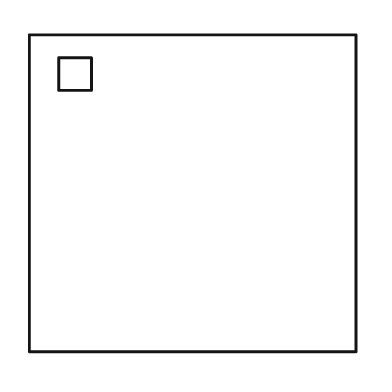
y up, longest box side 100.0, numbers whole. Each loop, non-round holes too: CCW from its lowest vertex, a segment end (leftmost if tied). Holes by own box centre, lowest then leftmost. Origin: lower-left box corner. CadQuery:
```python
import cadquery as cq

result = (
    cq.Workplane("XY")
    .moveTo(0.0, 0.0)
    .lineTo(100.0, 0.0)
    .lineTo(100.0, 97.0)
    .lineTo(0.0, 97.0)
    .close()
    .moveTo(9.0, 80.0)
    .lineTo(19.0, 80.0)
    .lineTo(19.0, 90.0)
    .lineTo(9.0, 90.0)
    .close()
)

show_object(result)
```